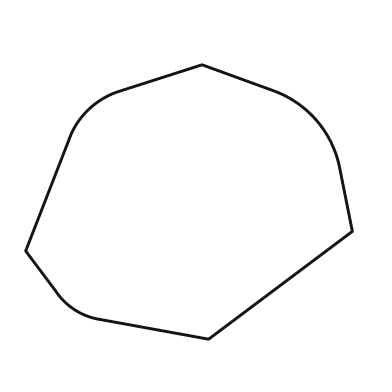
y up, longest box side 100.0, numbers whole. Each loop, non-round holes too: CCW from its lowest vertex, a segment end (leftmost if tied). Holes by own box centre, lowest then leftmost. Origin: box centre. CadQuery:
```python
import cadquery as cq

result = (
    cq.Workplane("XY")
    .moveTo(6.0, -42.0)
    .lineTo(50.0, -9.0)
    .lineTo(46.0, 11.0)
    .threePointArc((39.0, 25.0), (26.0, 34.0))
    .lineTo(4.0, 42.0)
    .lineTo(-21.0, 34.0)
    .threePointArc((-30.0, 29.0), (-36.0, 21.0))
    .lineTo(-50.0, -15.0)
    .lineTo(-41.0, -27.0)
    .threePointArc((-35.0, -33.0), (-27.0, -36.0))
    .close()
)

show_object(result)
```